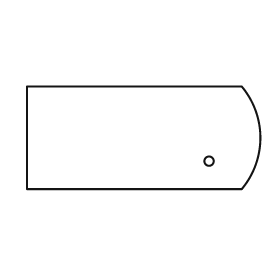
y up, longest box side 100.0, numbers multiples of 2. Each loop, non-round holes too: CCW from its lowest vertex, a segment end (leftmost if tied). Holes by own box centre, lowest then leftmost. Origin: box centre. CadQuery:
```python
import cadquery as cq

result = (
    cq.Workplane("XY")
    .moveTo(-50.0, -22.0)
    .lineTo(42.0, -22.0)
    .threePointArc((50.0, 0.0), (42.0, 22.0))
    .lineTo(-50.0, 22.0)
    .close()
    .moveTo(28.0, -10.0)
    .circle(2.0)
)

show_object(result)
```